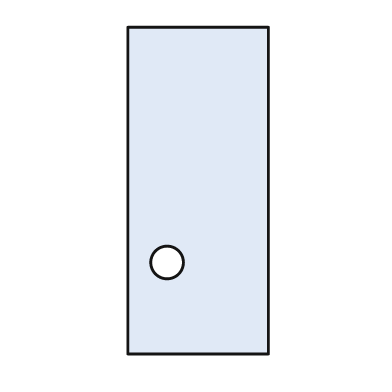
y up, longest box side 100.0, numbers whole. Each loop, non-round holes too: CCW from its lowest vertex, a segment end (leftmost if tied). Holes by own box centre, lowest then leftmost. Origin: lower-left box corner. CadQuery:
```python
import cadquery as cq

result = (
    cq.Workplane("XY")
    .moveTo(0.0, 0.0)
    .lineTo(43.0, 0.0)
    .lineTo(43.0, 100.0)
    .lineTo(0.0, 100.0)
    .close()
    .moveTo(12.0, 28.0)
    .circle(5.0)
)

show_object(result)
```